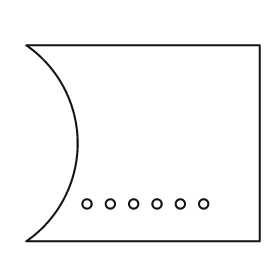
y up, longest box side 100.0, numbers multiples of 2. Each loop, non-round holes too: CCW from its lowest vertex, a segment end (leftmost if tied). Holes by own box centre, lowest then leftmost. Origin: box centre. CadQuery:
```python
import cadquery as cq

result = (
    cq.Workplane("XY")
    .moveTo(-50.0, -42.0)
    .lineTo(50.0, -42.0)
    .lineTo(50.0, 42.0)
    .lineTo(-50.0, 42.0)
    .threePointArc((-28.0, 0.0), (-50.0, -42.0))
    .close()
    .moveTo(-24.0, -26.0)
    .circle(2.0)
    .moveTo(-14.0, -26.0)
    .circle(2.0)
    .moveTo(-4.0, -26.0)
    .circle(2.0)
    .moveTo(6.0, -26.0)
    .circle(2.0)
    .moveTo(16.0, -26.0)
    .circle(2.0)
    .moveTo(26.0, -26.0)
    .circle(2.0)
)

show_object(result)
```